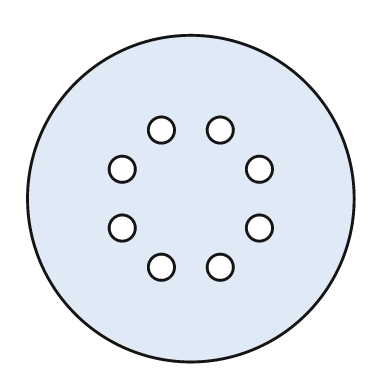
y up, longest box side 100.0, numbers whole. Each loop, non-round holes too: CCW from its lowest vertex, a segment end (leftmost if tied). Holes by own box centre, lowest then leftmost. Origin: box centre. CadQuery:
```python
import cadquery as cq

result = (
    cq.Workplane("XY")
    .moveTo(0.0, 0.0)
    .circle(50.0)
    .moveTo(-9.0, -21.0)
    .circle(4.0)
    .moveTo(9.0, -21.0)
    .circle(4.0)
    .moveTo(-21.0, -9.0)
    .circle(4.0)
    .moveTo(21.0, -9.0)
    .circle(4.0)
    .moveTo(-21.0, 9.0)
    .circle(4.0)
    .moveTo(21.0, 9.0)
    .circle(4.0)
    .moveTo(-9.0, 21.0)
    .circle(4.0)
    .moveTo(9.0, 21.0)
    .circle(4.0)
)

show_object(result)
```